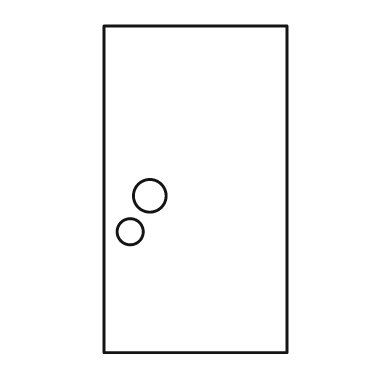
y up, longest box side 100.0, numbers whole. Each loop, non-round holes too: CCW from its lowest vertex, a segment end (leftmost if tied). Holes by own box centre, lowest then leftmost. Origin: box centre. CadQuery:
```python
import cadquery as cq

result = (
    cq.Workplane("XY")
    .moveTo(-28.0, -50.0)
    .lineTo(28.0, -50.0)
    .lineTo(28.0, 50.0)
    .lineTo(-28.0, 50.0)
    .close()
    .moveTo(-20.0, -13.0)
    .circle(4.0)
    .moveTo(-14.0, -2.0)
    .circle(5.0)
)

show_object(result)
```